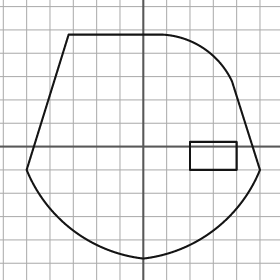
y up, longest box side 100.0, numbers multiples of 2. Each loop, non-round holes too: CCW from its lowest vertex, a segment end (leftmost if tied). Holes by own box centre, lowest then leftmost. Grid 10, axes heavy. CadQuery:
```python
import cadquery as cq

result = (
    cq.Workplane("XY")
    .moveTo(0.0, -48.0)
    .threePointArc((30.0, -36.0), (50.0, -10.0))
    .lineTo(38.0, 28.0)
    .threePointArc((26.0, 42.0), (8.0, 48.0))
    .lineTo(-32.0, 48.0)
    .lineTo(-50.0, -10.0)
    .threePointArc((-30.0, -36.0), (0.0, -48.0))
    .close()
    .moveTo(20.0, -10.0)
    .lineTo(40.0, -10.0)
    .lineTo(40.0, 2.0)
    .lineTo(20.0, 2.0)
    .close()
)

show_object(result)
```